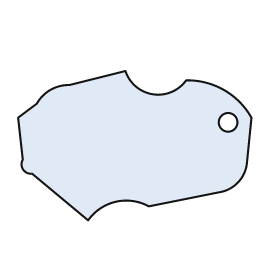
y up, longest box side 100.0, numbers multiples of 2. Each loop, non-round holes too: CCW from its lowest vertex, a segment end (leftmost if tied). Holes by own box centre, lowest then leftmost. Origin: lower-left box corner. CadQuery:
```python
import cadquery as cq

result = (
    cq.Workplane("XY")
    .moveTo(30.0, 0.0)
    .threePointArc((42.0, 8.0), (56.0, 6.0))
    .lineTo(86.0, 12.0)
    .threePointArc((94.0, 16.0), (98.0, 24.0))
    .lineTo(100.0, 44.0)
    .threePointArc((88.0, 56.0), (72.0, 60.0))
    .threePointArc((58.0, 54.0), (46.0, 64.0))
    .lineTo(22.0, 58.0)
    .threePointArc((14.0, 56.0), (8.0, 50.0))
    .lineTo(0.0, 44.0)
    .lineTo(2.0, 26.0)
    .threePointArc((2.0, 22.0), (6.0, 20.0))
    .close()
    .moveTo(90.0, 42.0)
    .circle(4.0)
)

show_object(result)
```